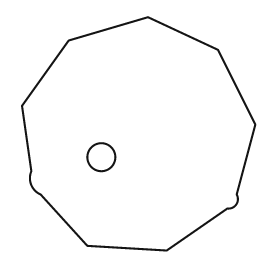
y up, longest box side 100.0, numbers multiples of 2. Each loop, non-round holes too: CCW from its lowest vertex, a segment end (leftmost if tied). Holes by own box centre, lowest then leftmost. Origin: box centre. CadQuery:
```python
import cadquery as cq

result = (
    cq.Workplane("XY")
    .moveTo(12.0, -50.0)
    .lineTo(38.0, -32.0)
    .threePointArc((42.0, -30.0), (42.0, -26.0))
    .lineTo(50.0, 4.0)
    .lineTo(34.0, 36.0)
    .lineTo(4.0, 50.0)
    .lineTo(-30.0, 40.0)
    .lineTo(-50.0, 12.0)
    .lineTo(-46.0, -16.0)
    .threePointArc((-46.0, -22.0), (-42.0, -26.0))
    .lineTo(-22.0, -48.0)
    .close()
    .moveTo(-16.0, -10.0)
    .circle(6.0)
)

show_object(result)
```